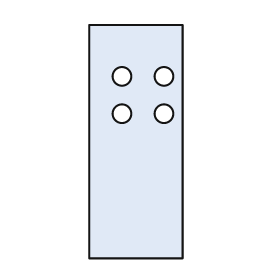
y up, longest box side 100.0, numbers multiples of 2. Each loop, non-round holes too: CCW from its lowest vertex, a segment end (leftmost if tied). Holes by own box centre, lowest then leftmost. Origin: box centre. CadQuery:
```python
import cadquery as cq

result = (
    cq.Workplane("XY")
    .moveTo(-20.0, -50.0)
    .lineTo(20.0, -50.0)
    .lineTo(20.0, 50.0)
    .lineTo(-20.0, 50.0)
    .close()
    .moveTo(-6.0, 12.0)
    .circle(4.0)
    .moveTo(12.0, 12.0)
    .circle(4.0)
    .moveTo(-6.0, 28.0)
    .circle(4.0)
    .moveTo(12.0, 28.0)
    .circle(4.0)
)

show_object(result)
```